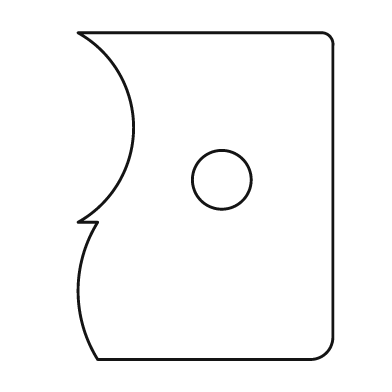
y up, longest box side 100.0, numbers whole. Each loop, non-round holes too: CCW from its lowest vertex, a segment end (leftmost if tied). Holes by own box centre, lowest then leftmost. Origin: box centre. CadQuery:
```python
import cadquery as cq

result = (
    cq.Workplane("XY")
    .moveTo(-33.0, -50.0)
    .lineTo(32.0, -50.0)
    .threePointArc((37.0, -48.0), (39.0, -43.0))
    .lineTo(39.0, 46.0)
    .threePointArc((38.0, 49.0), (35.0, 50.0))
    .lineTo(-39.0, 50.0)
    .threePointArc((-22.0, 21.0), (-39.0, -8.0))
    .lineTo(-33.0, -8.0)
    .threePointArc((-39.0, -29.0), (-33.0, -50.0))
    .close()
    .moveTo(5.0, 5.0)
    .circle(9.0)
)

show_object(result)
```